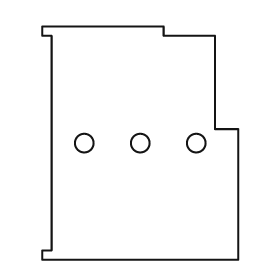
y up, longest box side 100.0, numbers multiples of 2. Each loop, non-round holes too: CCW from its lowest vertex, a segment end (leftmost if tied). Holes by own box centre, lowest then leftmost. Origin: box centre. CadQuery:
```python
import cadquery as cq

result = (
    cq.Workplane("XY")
    .moveTo(-42.0, -50.0)
    .lineTo(42.0, -50.0)
    .lineTo(42.0, 6.0)
    .lineTo(32.0, 6.0)
    .lineTo(32.0, 46.0)
    .lineTo(10.0, 46.0)
    .lineTo(10.0, 50.0)
    .lineTo(-42.0, 50.0)
    .lineTo(-42.0, 46.0)
    .lineTo(-38.0, 46.0)
    .lineTo(-38.0, -46.0)
    .lineTo(-42.0, -46.0)
    .close()
    .moveTo(-24.0, 0.0)
    .circle(4.0)
    .moveTo(0.0, 0.0)
    .circle(4.0)
    .moveTo(24.0, 0.0)
    .circle(4.0)
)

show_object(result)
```